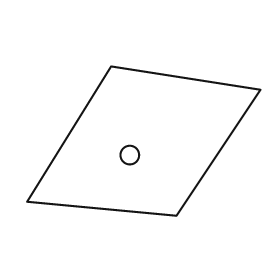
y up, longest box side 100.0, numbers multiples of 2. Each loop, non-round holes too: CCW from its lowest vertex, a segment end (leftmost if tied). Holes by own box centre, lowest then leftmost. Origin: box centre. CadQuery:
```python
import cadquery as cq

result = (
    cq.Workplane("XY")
    .moveTo(14.0, -32.0)
    .lineTo(50.0, 22.0)
    .lineTo(-14.0, 32.0)
    .lineTo(-50.0, -26.0)
    .close()
    .moveTo(-6.0, -6.0)
    .circle(4.0)
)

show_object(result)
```